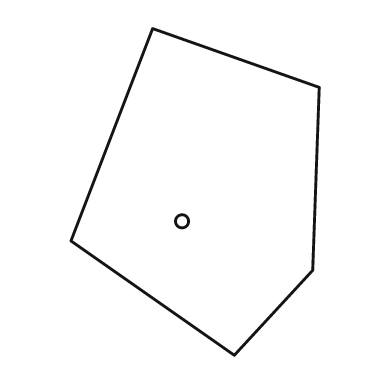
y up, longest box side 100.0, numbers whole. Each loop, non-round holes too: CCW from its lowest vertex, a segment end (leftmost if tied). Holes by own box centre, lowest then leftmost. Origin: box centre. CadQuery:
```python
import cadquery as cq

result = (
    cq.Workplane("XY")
    .moveTo(12.0, -50.0)
    .lineTo(36.0, -24.0)
    .lineTo(38.0, 32.0)
    .lineTo(-13.0, 50.0)
    .lineTo(-38.0, -15.0)
    .close()
    .moveTo(-4.0, -9.0)
    .circle(2.0)
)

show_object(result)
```